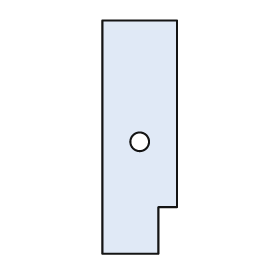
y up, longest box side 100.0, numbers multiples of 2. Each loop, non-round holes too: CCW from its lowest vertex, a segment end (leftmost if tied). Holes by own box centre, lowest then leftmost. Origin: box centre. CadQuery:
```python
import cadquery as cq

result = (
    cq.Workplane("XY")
    .moveTo(-16.0, -50.0)
    .lineTo(8.0, -50.0)
    .lineTo(8.0, -30.0)
    .lineTo(16.0, -30.0)
    .lineTo(16.0, 50.0)
    .lineTo(-16.0, 50.0)
    .close()
    .moveTo(0.0, -2.0)
    .circle(4.0)
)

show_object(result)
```